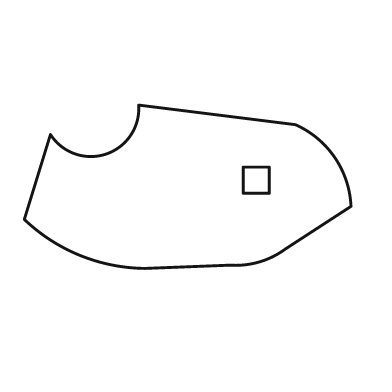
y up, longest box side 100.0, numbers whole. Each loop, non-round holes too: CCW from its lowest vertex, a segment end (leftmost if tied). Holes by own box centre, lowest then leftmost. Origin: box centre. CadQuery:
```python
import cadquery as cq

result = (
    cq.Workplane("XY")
    .moveTo(-13.0, -25.0)
    .lineTo(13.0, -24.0)
    .threePointArc((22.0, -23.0), (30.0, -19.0))
    .lineTo(50.0, -6.0)
    .threePointArc((45.0, 9.0), (33.0, 19.0))
    .lineTo(-15.0, 25.0)
    .threePointArc((-25.0, 10.0), (-42.0, 16.0))
    .lineTo(-50.0, -10.0)
    .threePointArc((-33.0, -21.0), (-13.0, -25.0))
    .close()
    .moveTo(17.0, -2.0)
    .lineTo(25.0, -2.0)
    .lineTo(25.0, 6.0)
    .lineTo(17.0, 6.0)
    .close()
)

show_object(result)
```